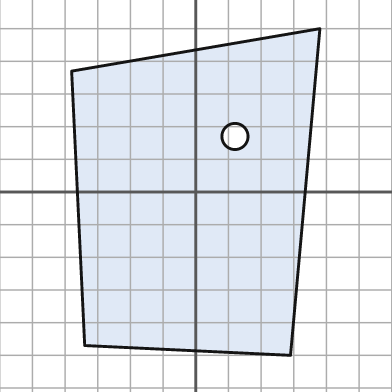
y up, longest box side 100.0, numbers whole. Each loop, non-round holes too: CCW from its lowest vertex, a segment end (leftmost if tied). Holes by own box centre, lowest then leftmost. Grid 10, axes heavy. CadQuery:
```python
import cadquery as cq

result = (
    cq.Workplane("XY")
    .moveTo(29.0, -50.0)
    .lineTo(38.0, 50.0)
    .lineTo(-38.0, 37.0)
    .lineTo(-34.0, -47.0)
    .close()
    .moveTo(12.0, 17.0)
    .circle(4.0)
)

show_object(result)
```